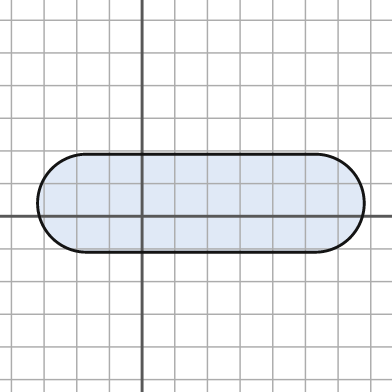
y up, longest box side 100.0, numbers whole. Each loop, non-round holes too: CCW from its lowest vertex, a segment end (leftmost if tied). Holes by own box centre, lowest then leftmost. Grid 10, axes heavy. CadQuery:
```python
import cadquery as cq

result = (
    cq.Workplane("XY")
    .moveTo(-17.0, -11.0)
    .lineTo(53.0, -11.0)
    .threePointArc((68.0, 4.0), (53.0, 19.0))
    .lineTo(-17.0, 19.0)
    .threePointArc((-32.0, 4.0), (-17.0, -11.0))
    .close()
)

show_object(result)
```